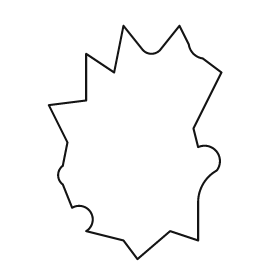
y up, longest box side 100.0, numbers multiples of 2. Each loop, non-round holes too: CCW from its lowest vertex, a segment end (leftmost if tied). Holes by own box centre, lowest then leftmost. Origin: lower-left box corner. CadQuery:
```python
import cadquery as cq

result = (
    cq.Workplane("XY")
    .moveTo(38.0, 0.0)
    .lineTo(52.0, 12.0)
    .lineTo(64.0, 8.0)
    .lineTo(64.0, 24.0)
    .threePointArc((66.0, 32.0), (72.0, 38.0))
    .threePointArc((72.0, 46.0), (64.0, 48.0))
    .lineTo(62.0, 56.0)
    .lineTo(74.0, 80.0)
    .lineTo(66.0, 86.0)
    .threePointArc((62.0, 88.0), (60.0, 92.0))
    .lineTo(56.0, 100.0)
    .lineTo(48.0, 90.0)
    .threePointArc((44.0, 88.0), (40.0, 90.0))
    .lineTo(32.0, 100.0)
    .lineTo(28.0, 80.0)
    .lineTo(16.0, 88.0)
    .lineTo(16.0, 68.0)
    .lineTo(0.0, 66.0)
    .lineTo(8.0, 50.0)
    .lineTo(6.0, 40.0)
    .threePointArc((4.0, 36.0), (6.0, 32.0))
    .lineTo(10.0, 22.0)
    .threePointArc((18.0, 20.0), (16.0, 12.0))
    .lineTo(32.0, 8.0)
    .close()
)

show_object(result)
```